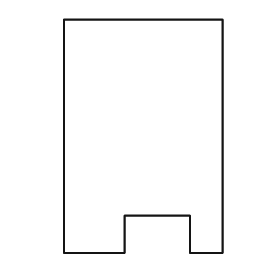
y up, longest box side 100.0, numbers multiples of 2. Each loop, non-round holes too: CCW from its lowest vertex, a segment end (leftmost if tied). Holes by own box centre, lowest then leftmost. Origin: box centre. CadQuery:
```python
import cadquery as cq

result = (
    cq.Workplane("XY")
    .moveTo(-34.0, -50.0)
    .lineTo(-8.0, -50.0)
    .lineTo(-8.0, -34.0)
    .lineTo(20.0, -34.0)
    .lineTo(20.0, -50.0)
    .lineTo(34.0, -50.0)
    .lineTo(34.0, 50.0)
    .lineTo(-34.0, 50.0)
    .close()
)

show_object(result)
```